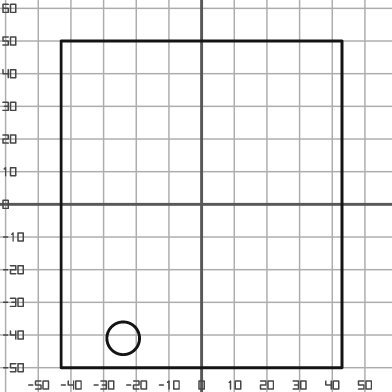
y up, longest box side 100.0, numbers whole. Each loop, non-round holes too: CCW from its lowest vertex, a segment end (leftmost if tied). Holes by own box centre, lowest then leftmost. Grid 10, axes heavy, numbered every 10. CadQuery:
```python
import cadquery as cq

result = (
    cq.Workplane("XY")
    .moveTo(-43.0, -50.0)
    .lineTo(43.0, -50.0)
    .lineTo(43.0, 50.0)
    .lineTo(-43.0, 50.0)
    .close()
    .moveTo(-24.0, -41.0)
    .circle(5.0)
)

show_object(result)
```